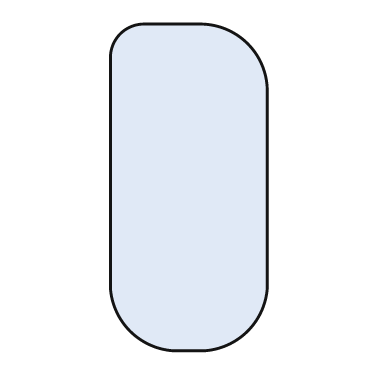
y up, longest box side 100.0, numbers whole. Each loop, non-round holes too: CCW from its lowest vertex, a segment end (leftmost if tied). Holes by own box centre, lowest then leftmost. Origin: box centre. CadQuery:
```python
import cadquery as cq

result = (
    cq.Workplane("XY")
    .moveTo(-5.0, -50.0)
    .lineTo(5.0, -50.0)
    .threePointArc((18.0, -44.0), (24.0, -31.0))
    .lineTo(24.0, 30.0)
    .threePointArc((18.0, 44.0), (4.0, 50.0))
    .lineTo(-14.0, 50.0)
    .threePointArc((-21.0, 47.0), (-24.0, 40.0))
    .lineTo(-24.0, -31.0)
    .threePointArc((-18.0, -44.0), (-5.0, -50.0))
    .close()
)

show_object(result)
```